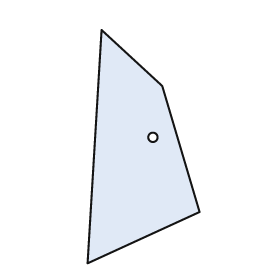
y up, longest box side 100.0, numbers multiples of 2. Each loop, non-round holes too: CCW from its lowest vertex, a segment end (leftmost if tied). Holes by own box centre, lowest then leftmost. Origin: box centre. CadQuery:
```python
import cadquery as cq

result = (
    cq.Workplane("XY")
    .moveTo(-24.0, -50.0)
    .lineTo(24.0, -28.0)
    .lineTo(8.0, 26.0)
    .lineTo(-18.0, 50.0)
    .close()
    .moveTo(4.0, 4.0)
    .circle(2.0)
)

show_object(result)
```